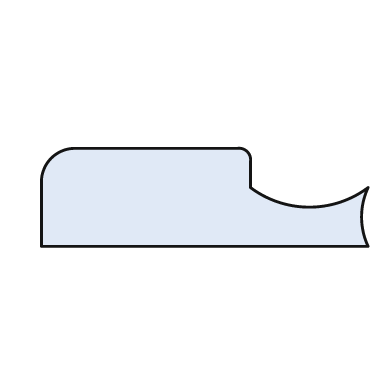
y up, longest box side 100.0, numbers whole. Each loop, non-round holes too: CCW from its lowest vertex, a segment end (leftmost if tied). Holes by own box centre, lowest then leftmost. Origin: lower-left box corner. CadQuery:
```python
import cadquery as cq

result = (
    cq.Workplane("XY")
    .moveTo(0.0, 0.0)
    .lineTo(100.0, 0.0)
    .threePointArc((98.0, 9.0), (100.0, 18.0))
    .threePointArc((82.0, 12.0), (64.0, 18.0))
    .lineTo(64.0, 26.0)
    .threePointArc((63.0, 29.0), (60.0, 30.0))
    .lineTo(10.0, 30.0)
    .threePointArc((3.0, 27.0), (0.0, 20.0))
    .close()
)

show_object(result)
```